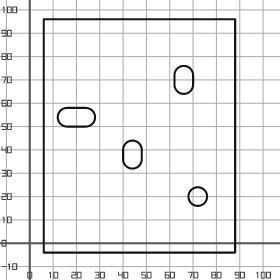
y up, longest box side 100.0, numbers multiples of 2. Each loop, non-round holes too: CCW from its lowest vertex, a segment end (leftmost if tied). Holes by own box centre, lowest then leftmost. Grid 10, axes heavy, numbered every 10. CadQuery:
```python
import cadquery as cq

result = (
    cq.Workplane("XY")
    .moveTo(6.0, -4.0)
    .lineTo(88.0, -4.0)
    .lineTo(88.0, 96.0)
    .lineTo(6.0, 96.0)
    .close()
    .moveTo(72.0, 20.0)
    .circle(4.0)
    .moveTo(40.0, 36.0)
    .threePointArc((44.0, 32.0), (48.0, 36.0))
    .lineTo(48.0, 40.0)
    .threePointArc((44.0, 44.0), (40.0, 40.0))
    .close()
    .moveTo(16.0, 50.0)
    .lineTo(24.0, 50.0)
    .threePointArc((28.0, 54.0), (24.0, 58.0))
    .lineTo(16.0, 58.0)
    .threePointArc((12.0, 54.0), (16.0, 50.0))
    .close()
    .moveTo(62.0, 68.0)
    .threePointArc((66.0, 64.0), (70.0, 68.0))
    .lineTo(70.0, 72.0)
    .threePointArc((66.0, 76.0), (62.0, 72.0))
    .close()
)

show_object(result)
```